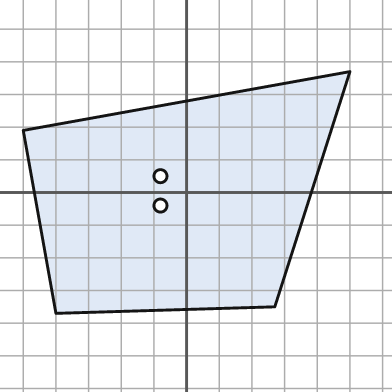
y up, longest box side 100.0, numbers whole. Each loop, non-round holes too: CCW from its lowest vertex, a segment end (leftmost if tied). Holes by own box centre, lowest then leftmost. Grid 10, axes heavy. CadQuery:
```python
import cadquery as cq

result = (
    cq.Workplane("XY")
    .moveTo(-40.0, -37.0)
    .lineTo(27.0, -35.0)
    .lineTo(50.0, 37.0)
    .lineTo(-50.0, 19.0)
    .close()
    .moveTo(-8.0, -4.0)
    .circle(2.0)
    .moveTo(-8.0, 5.0)
    .circle(2.0)
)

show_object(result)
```